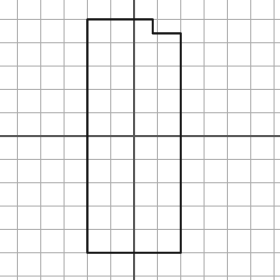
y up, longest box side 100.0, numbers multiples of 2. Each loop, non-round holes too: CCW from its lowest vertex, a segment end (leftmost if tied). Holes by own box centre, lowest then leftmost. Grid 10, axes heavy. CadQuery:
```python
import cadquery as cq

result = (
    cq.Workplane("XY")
    .moveTo(-20.0, -50.0)
    .lineTo(20.0, -50.0)
    .lineTo(20.0, 44.0)
    .lineTo(8.0, 44.0)
    .lineTo(8.0, 50.0)
    .lineTo(-20.0, 50.0)
    .close()
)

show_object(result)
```